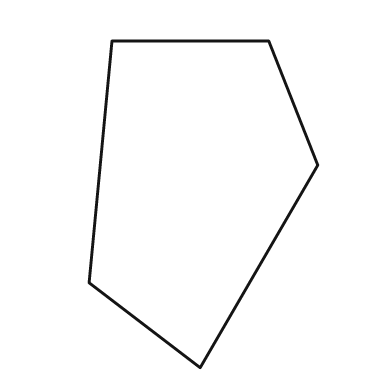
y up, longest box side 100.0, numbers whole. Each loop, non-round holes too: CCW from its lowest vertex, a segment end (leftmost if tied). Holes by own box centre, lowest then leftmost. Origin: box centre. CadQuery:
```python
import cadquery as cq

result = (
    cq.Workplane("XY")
    .moveTo(-1.0, -50.0)
    .lineTo(35.0, 12.0)
    .lineTo(20.0, 50.0)
    .lineTo(-28.0, 50.0)
    .lineTo(-35.0, -24.0)
    .close()
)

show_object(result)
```